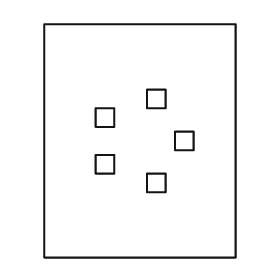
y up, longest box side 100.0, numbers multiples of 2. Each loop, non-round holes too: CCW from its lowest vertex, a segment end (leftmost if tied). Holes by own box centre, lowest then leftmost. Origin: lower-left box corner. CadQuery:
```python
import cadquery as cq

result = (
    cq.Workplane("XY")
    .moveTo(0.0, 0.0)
    .lineTo(82.0, 0.0)
    .lineTo(82.0, 100.0)
    .lineTo(0.0, 100.0)
    .close()
    .moveTo(44.0, 28.0)
    .lineTo(52.0, 28.0)
    .lineTo(52.0, 36.0)
    .lineTo(44.0, 36.0)
    .close()
    .moveTo(22.0, 36.0)
    .lineTo(30.0, 36.0)
    .lineTo(30.0, 44.0)
    .lineTo(22.0, 44.0)
    .close()
    .moveTo(56.0, 46.0)
    .lineTo(64.0, 46.0)
    .lineTo(64.0, 54.0)
    .lineTo(56.0, 54.0)
    .close()
    .moveTo(22.0, 56.0)
    .lineTo(30.0, 56.0)
    .lineTo(30.0, 64.0)
    .lineTo(22.0, 64.0)
    .close()
    .moveTo(44.0, 64.0)
    .lineTo(52.0, 64.0)
    .lineTo(52.0, 72.0)
    .lineTo(44.0, 72.0)
    .close()
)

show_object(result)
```